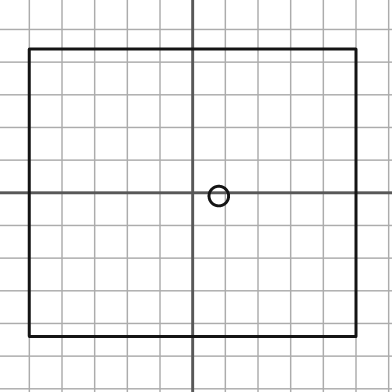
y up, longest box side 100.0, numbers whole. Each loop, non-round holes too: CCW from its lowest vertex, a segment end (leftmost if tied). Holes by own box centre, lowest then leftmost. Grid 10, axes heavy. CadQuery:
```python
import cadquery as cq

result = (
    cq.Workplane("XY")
    .moveTo(-50.0, -44.0)
    .lineTo(50.0, -44.0)
    .lineTo(50.0, 44.0)
    .lineTo(-50.0, 44.0)
    .close()
    .moveTo(8.0, -1.0)
    .circle(3.0)
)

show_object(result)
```